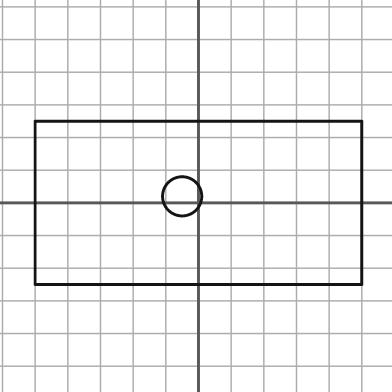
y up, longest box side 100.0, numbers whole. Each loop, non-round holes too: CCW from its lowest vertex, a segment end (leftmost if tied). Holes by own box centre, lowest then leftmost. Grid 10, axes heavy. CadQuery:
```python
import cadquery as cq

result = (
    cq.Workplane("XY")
    .moveTo(-50.0, -25.0)
    .lineTo(50.0, -25.0)
    .lineTo(50.0, 25.0)
    .lineTo(-50.0, 25.0)
    .close()
    .moveTo(-5.0, 2.0)
    .circle(6.0)
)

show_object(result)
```